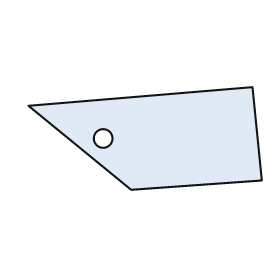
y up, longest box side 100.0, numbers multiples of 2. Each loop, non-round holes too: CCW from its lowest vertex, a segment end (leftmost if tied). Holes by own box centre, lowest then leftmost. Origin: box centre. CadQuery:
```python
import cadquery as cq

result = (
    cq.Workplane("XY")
    .moveTo(-6.0, -22.0)
    .lineTo(50.0, -18.0)
    .lineTo(46.0, 22.0)
    .lineTo(-50.0, 14.0)
    .close()
    .moveTo(-18.0, 0.0)
    .circle(4.0)
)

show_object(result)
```